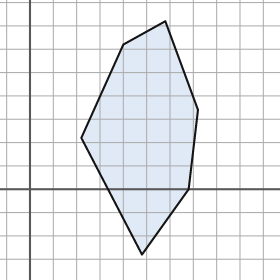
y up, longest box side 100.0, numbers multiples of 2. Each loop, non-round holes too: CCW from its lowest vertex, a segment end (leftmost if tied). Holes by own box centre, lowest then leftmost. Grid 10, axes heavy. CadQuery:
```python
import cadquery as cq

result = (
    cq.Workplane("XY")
    .moveTo(48.0, -28.0)
    .lineTo(68.0, 0.0)
    .lineTo(72.0, 34.0)
    .lineTo(58.0, 72.0)
    .lineTo(40.0, 62.0)
    .lineTo(22.0, 22.0)
    .close()
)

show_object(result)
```